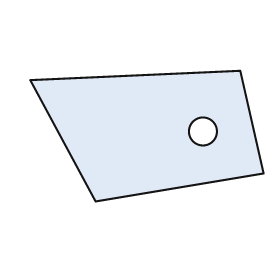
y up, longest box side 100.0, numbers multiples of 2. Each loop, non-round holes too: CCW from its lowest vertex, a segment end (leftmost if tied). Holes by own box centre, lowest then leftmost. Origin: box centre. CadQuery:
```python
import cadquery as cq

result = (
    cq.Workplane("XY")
    .moveTo(-22.0, -28.0)
    .lineTo(50.0, -16.0)
    .lineTo(40.0, 28.0)
    .lineTo(-50.0, 24.0)
    .close()
    .moveTo(24.0, 2.0)
    .circle(6.0)
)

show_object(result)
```